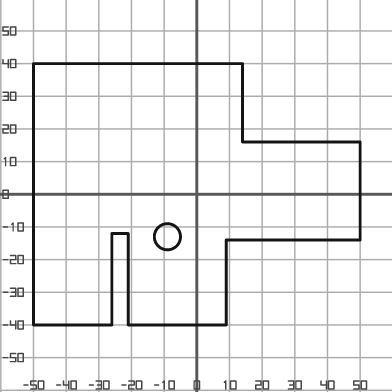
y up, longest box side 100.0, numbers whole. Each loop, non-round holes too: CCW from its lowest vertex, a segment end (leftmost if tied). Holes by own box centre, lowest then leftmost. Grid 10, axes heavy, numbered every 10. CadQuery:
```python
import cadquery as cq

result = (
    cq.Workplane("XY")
    .moveTo(-50.0, -40.0)
    .lineTo(-26.0, -40.0)
    .lineTo(-26.0, -12.0)
    .lineTo(-21.0, -12.0)
    .lineTo(-21.0, -40.0)
    .lineTo(9.0, -40.0)
    .lineTo(9.0, -14.0)
    .lineTo(50.0, -14.0)
    .lineTo(50.0, 16.0)
    .lineTo(14.0, 16.0)
    .lineTo(14.0, 40.0)
    .lineTo(-50.0, 40.0)
    .close()
    .moveTo(-9.0, -13.0)
    .circle(4.0)
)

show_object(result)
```